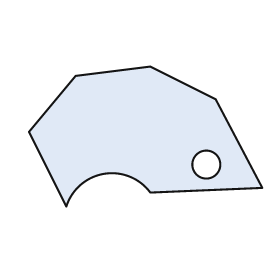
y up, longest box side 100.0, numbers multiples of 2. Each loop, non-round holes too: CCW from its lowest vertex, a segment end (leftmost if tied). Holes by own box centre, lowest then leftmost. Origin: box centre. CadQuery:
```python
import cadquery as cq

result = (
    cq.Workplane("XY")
    .moveTo(-34.0, -30.0)
    .threePointArc((-18.0, -16.0), (2.0, -24.0))
    .lineTo(50.0, -22.0)
    .lineTo(30.0, 16.0)
    .lineTo(2.0, 30.0)
    .lineTo(-30.0, 26.0)
    .lineTo(-50.0, 2.0)
    .close()
    .moveTo(26.0, -12.0)
    .circle(6.0)
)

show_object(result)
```